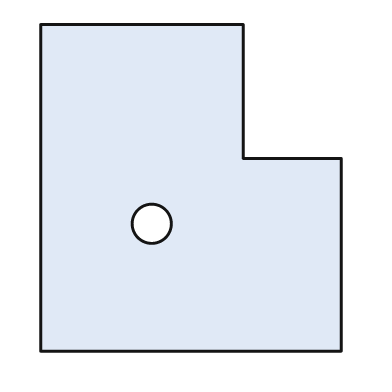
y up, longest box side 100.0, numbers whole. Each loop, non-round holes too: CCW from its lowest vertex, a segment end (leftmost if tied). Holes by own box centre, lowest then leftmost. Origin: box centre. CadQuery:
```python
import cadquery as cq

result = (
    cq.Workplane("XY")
    .moveTo(-46.0, -50.0)
    .lineTo(46.0, -50.0)
    .lineTo(46.0, 9.0)
    .lineTo(16.0, 9.0)
    .lineTo(16.0, 50.0)
    .lineTo(-46.0, 50.0)
    .close()
    .moveTo(-12.0, -11.0)
    .circle(6.0)
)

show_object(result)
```